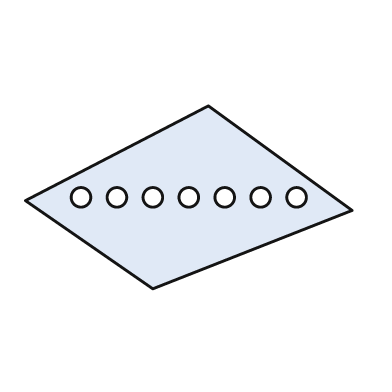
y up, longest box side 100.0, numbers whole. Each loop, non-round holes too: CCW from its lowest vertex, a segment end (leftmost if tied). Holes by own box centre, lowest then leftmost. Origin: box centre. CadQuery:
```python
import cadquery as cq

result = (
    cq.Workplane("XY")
    .moveTo(-11.0, -28.0)
    .lineTo(50.0, -4.0)
    .lineTo(6.0, 28.0)
    .lineTo(-50.0, -1.0)
    .close()
    .moveTo(-33.0, 0.0)
    .circle(3.0)
    .moveTo(-22.0, 0.0)
    .circle(3.0)
    .moveTo(-11.0, 0.0)
    .circle(3.0)
    .moveTo(0.0, 0.0)
    .circle(3.0)
    .moveTo(11.0, 0.0)
    .circle(3.0)
    .moveTo(22.0, 0.0)
    .circle(3.0)
    .moveTo(33.0, 0.0)
    .circle(3.0)
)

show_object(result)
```